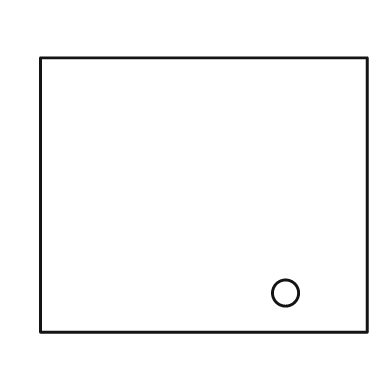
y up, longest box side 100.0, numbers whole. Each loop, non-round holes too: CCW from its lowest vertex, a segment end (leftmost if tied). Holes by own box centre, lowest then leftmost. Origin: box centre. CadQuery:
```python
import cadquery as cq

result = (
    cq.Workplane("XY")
    .moveTo(-50.0, -42.0)
    .lineTo(50.0, -42.0)
    .lineTo(50.0, 42.0)
    .lineTo(-50.0, 42.0)
    .close()
    .moveTo(25.0, -30.0)
    .circle(4.0)
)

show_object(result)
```